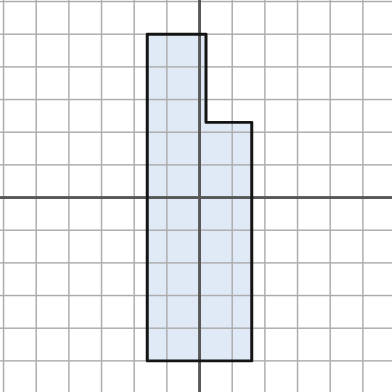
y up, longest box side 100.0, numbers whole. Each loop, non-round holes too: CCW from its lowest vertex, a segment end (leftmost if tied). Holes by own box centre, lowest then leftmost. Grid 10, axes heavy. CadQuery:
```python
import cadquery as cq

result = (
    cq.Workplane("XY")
    .moveTo(-16.0, -50.0)
    .lineTo(16.0, -50.0)
    .lineTo(16.0, 23.0)
    .lineTo(2.0, 23.0)
    .lineTo(2.0, 50.0)
    .lineTo(-16.0, 50.0)
    .close()
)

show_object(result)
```